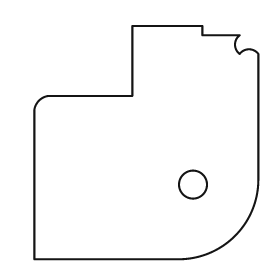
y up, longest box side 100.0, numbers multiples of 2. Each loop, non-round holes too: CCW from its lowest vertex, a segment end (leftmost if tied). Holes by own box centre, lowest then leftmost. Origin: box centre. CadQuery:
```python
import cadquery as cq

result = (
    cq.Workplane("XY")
    .moveTo(-48.0, -50.0)
    .lineTo(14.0, -50.0)
    .threePointArc((38.0, -40.0), (48.0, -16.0))
    .lineTo(48.0, 38.0)
    .threePointArc((44.0, 40.0), (40.0, 38.0))
    .threePointArc((38.0, 42.0), (40.0, 46.0))
    .lineTo(24.0, 46.0)
    .lineTo(24.0, 50.0)
    .lineTo(-6.0, 50.0)
    .lineTo(-6.0, 20.0)
    .lineTo(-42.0, 20.0)
    .threePointArc((-46.0, 18.0), (-48.0, 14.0))
    .close()
    .moveTo(20.0, -18.0)
    .circle(6.0)
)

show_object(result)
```